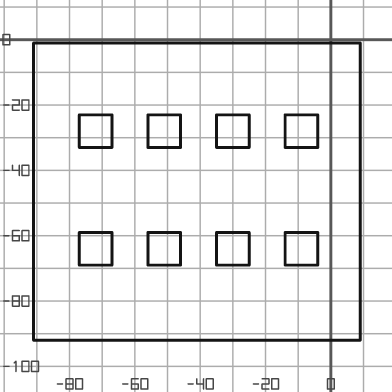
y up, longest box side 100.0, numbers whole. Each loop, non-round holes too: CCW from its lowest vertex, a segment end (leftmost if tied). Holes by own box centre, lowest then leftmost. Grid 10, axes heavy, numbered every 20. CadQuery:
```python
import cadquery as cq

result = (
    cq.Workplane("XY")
    .moveTo(-91.0, -92.0)
    .lineTo(9.0, -92.0)
    .lineTo(9.0, -1.0)
    .lineTo(-91.0, -1.0)
    .close()
    .moveTo(-77.0, -69.0)
    .lineTo(-67.0, -69.0)
    .lineTo(-67.0, -59.0)
    .lineTo(-77.0, -59.0)
    .close()
    .moveTo(-56.0, -69.0)
    .lineTo(-46.0, -69.0)
    .lineTo(-46.0, -59.0)
    .lineTo(-56.0, -59.0)
    .close()
    .moveTo(-35.0, -69.0)
    .lineTo(-25.0, -69.0)
    .lineTo(-25.0, -59.0)
    .lineTo(-35.0, -59.0)
    .close()
    .moveTo(-14.0, -69.0)
    .lineTo(-4.0, -69.0)
    .lineTo(-4.0, -59.0)
    .lineTo(-14.0, -59.0)
    .close()
    .moveTo(-77.0, -33.0)
    .lineTo(-67.0, -33.0)
    .lineTo(-67.0, -23.0)
    .lineTo(-77.0, -23.0)
    .close()
    .moveTo(-56.0, -33.0)
    .lineTo(-46.0, -33.0)
    .lineTo(-46.0, -23.0)
    .lineTo(-56.0, -23.0)
    .close()
    .moveTo(-35.0, -33.0)
    .lineTo(-25.0, -33.0)
    .lineTo(-25.0, -23.0)
    .lineTo(-35.0, -23.0)
    .close()
    .moveTo(-14.0, -33.0)
    .lineTo(-4.0, -33.0)
    .lineTo(-4.0, -23.0)
    .lineTo(-14.0, -23.0)
    .close()
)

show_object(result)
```